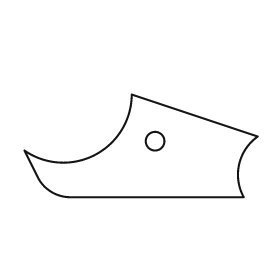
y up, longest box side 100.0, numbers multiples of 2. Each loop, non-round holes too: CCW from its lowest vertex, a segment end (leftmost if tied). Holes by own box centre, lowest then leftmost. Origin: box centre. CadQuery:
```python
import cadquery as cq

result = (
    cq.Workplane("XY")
    .moveTo(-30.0, -22.0)
    .lineTo(44.0, -22.0)
    .threePointArc((42.0, -8.0), (50.0, 4.0))
    .lineTo(-4.0, 22.0)
    .threePointArc((-20.0, -4.0), (-50.0, -2.0))
    .lineTo(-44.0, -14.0)
    .threePointArc((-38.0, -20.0), (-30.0, -22.0))
    .close()
    .moveTo(6.0, 2.0)
    .circle(4.0)
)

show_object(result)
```